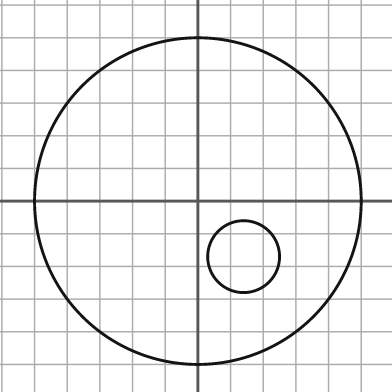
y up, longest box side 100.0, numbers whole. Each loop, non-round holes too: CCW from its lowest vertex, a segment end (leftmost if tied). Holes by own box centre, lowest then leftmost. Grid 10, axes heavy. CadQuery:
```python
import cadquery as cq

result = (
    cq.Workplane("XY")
    .moveTo(0.0, 0.0)
    .circle(50.0)
    .moveTo(14.0, -17.0)
    .circle(11.0)
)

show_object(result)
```